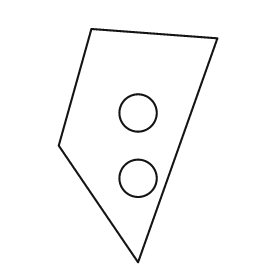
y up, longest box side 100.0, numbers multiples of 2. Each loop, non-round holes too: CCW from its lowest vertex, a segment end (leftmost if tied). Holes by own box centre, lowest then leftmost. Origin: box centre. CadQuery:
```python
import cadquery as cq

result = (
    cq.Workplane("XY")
    .moveTo(0.0, -50.0)
    .lineTo(34.0, 46.0)
    .lineTo(-20.0, 50.0)
    .lineTo(-34.0, 0.0)
    .close()
    .moveTo(0.0, -14.0)
    .circle(8.0)
    .moveTo(0.0, 14.0)
    .circle(8.0)
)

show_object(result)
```